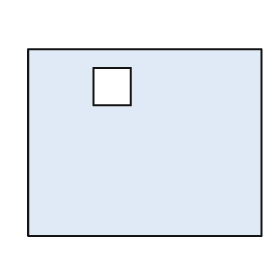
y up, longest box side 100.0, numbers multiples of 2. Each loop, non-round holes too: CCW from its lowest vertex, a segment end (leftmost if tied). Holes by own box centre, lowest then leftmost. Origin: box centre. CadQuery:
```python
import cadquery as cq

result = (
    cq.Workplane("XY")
    .moveTo(-50.0, -40.0)
    .lineTo(50.0, -40.0)
    .lineTo(50.0, 40.0)
    .lineTo(-50.0, 40.0)
    .close()
    .moveTo(-22.0, 16.0)
    .lineTo(-6.0, 16.0)
    .lineTo(-6.0, 32.0)
    .lineTo(-22.0, 32.0)
    .close()
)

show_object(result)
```